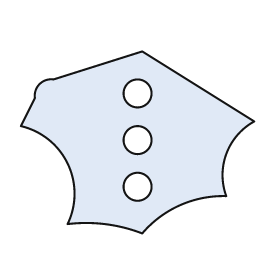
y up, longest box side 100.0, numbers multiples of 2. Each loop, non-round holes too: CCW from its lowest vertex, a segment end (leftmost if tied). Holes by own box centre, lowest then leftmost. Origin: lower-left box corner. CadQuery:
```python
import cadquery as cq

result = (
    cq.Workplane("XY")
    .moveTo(52.0, 0.0)
    .threePointArc((68.0, 12.0), (88.0, 16.0))
    .threePointArc((88.0, 34.0), (100.0, 48.0))
    .lineTo(52.0, 78.0)
    .lineTo(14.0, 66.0)
    .threePointArc((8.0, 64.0), (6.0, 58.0))
    .lineTo(0.0, 46.0)
    .threePointArc((20.0, 30.0), (20.0, 4.0))
    .threePointArc((36.0, 4.0), (52.0, 0.0))
    .close()
    .moveTo(50.0, 20.0)
    .circle(6.0)
    .moveTo(50.0, 40.0)
    .circle(6.0)
    .moveTo(50.0, 60.0)
    .circle(6.0)
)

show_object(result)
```